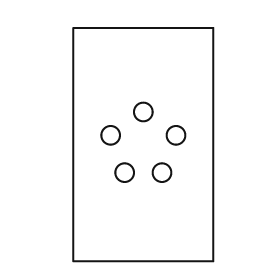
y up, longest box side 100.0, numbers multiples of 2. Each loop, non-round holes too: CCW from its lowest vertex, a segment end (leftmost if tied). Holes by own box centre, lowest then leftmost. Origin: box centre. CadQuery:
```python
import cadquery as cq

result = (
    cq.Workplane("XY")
    .moveTo(-30.0, -50.0)
    .lineTo(30.0, -50.0)
    .lineTo(30.0, 50.0)
    .lineTo(-30.0, 50.0)
    .close()
    .moveTo(-8.0, -12.0)
    .circle(4.0)
    .moveTo(8.0, -12.0)
    .circle(4.0)
    .moveTo(-14.0, 4.0)
    .circle(4.0)
    .moveTo(14.0, 4.0)
    .circle(4.0)
    .moveTo(0.0, 14.0)
    .circle(4.0)
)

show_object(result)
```